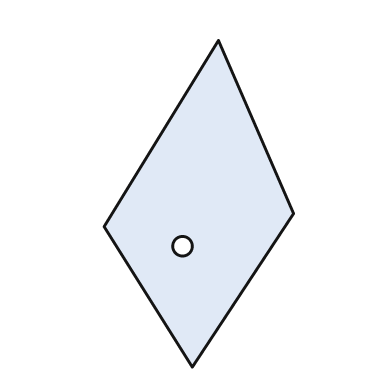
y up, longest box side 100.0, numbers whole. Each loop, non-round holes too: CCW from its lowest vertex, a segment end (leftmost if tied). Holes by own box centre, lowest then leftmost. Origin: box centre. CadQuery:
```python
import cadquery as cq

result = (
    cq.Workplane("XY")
    .moveTo(-2.0, -50.0)
    .lineTo(29.0, -3.0)
    .lineTo(6.0, 50.0)
    .lineTo(-29.0, -7.0)
    .close()
    .moveTo(-5.0, -13.0)
    .circle(3.0)
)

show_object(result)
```